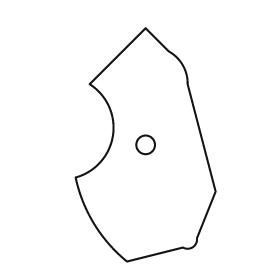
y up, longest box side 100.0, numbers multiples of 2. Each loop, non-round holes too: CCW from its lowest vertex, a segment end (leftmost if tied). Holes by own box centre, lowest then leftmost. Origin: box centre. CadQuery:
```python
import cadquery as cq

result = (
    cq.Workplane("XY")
    .moveTo(-8.0, -50.0)
    .lineTo(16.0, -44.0)
    .threePointArc((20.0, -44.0), (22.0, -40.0))
    .lineTo(30.0, -20.0)
    .lineTo(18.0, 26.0)
    .threePointArc((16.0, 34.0), (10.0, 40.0))
    .lineTo(0.0, 50.0)
    .lineTo(-24.0, 26.0)
    .threePointArc((-14.0, 4.0), (-30.0, -14.0))
    .threePointArc((-22.0, -34.0), (-8.0, -50.0))
    .close()
    .moveTo(0.0, 0.0)
    .circle(4.0)
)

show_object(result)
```